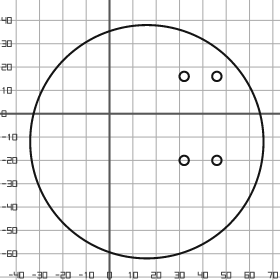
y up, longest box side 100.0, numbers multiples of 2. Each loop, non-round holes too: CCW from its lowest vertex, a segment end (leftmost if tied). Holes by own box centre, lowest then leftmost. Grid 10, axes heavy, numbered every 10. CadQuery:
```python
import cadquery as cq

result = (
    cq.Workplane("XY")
    .moveTo(16.0, -12.0)
    .circle(50.0)
    .moveTo(32.0, -20.0)
    .circle(2.0)
    .moveTo(46.0, -20.0)
    .circle(2.0)
    .moveTo(32.0, 16.0)
    .circle(2.0)
    .moveTo(46.0, 16.0)
    .circle(2.0)
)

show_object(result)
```